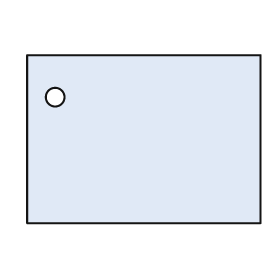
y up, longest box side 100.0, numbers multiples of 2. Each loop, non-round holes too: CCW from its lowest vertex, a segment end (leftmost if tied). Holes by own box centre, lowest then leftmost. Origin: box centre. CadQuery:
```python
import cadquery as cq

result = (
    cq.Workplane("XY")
    .moveTo(-50.0, -36.0)
    .lineTo(50.0, -36.0)
    .lineTo(50.0, 36.0)
    .lineTo(-50.0, 36.0)
    .close()
    .moveTo(-38.0, 18.0)
    .circle(4.0)
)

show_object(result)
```